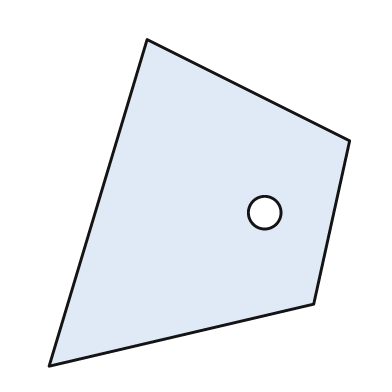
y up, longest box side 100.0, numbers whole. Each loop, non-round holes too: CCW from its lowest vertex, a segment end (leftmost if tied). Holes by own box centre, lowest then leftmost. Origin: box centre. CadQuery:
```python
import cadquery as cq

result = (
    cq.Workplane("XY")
    .moveTo(-46.0, -50.0)
    .lineTo(35.0, -31.0)
    .lineTo(46.0, 19.0)
    .lineTo(-16.0, 50.0)
    .close()
    .moveTo(20.0, -3.0)
    .circle(5.0)
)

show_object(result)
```